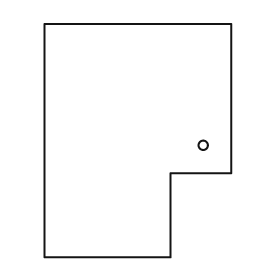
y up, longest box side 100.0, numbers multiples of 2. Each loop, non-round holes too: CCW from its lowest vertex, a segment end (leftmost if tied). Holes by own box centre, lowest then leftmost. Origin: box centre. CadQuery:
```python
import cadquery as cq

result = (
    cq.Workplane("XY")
    .moveTo(-40.0, -50.0)
    .lineTo(14.0, -50.0)
    .lineTo(14.0, -14.0)
    .lineTo(40.0, -14.0)
    .lineTo(40.0, 50.0)
    .lineTo(-40.0, 50.0)
    .close()
    .moveTo(28.0, -2.0)
    .circle(2.0)
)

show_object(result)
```